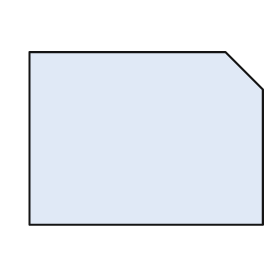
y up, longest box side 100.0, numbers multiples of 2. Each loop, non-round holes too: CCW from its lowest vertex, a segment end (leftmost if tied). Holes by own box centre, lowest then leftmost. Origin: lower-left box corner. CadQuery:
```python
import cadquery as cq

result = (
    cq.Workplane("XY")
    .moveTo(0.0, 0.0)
    .lineTo(100.0, 0.0)
    .lineTo(100.0, 58.0)
    .lineTo(84.0, 74.0)
    .lineTo(0.0, 74.0)
    .close()
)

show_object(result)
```